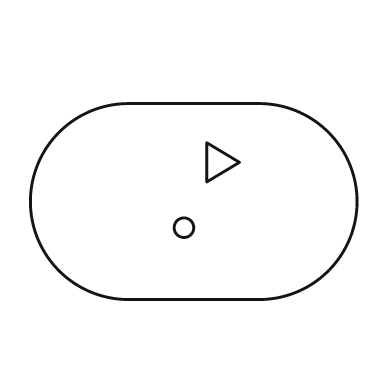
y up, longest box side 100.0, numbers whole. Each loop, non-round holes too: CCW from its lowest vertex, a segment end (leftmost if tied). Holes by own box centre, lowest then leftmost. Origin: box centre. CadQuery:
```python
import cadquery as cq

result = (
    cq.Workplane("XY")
    .moveTo(-20.0, -30.0)
    .lineTo(20.0, -30.0)
    .threePointArc((50.0, 0.0), (20.0, 30.0))
    .lineTo(-20.0, 30.0)
    .threePointArc((-50.0, 0.0), (-20.0, -30.0))
    .close()
    .moveTo(-3.0, -8.0)
    .circle(3.0)
    .moveTo(4.0, 6.0)
    .lineTo(14.0, 12.0)
    .lineTo(4.0, 18.0)
    .close()
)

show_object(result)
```